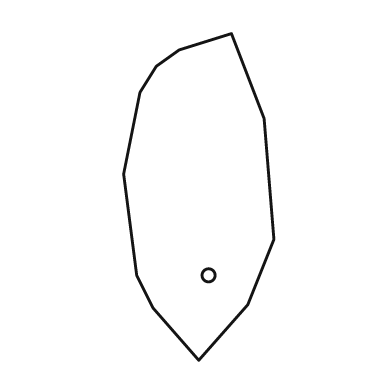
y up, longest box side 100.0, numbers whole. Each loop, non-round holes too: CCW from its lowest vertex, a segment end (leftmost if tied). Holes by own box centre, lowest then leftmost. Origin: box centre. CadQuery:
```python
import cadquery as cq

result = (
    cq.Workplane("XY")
    .moveTo(0.0, -50.0)
    .lineTo(15.0, -33.0)
    .lineTo(23.0, -13.0)
    .lineTo(20.0, 24.0)
    .lineTo(10.0, 50.0)
    .lineTo(-6.0, 45.0)
    .lineTo(-13.0, 40.0)
    .lineTo(-18.0, 32.0)
    .lineTo(-23.0, 7.0)
    .lineTo(-19.0, -24.0)
    .lineTo(-14.0, -34.0)
    .close()
    .moveTo(3.0, -24.0)
    .circle(2.0)
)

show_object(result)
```